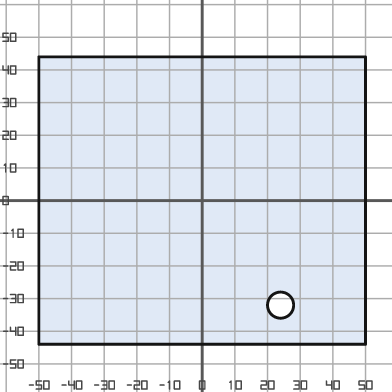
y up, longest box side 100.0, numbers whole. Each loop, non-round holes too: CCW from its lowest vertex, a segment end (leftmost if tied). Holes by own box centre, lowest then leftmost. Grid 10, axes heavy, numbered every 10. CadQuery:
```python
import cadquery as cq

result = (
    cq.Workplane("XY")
    .moveTo(-50.0, -44.0)
    .lineTo(50.0, -44.0)
    .lineTo(50.0, 44.0)
    .lineTo(-50.0, 44.0)
    .close()
    .moveTo(24.0, -32.0)
    .circle(4.0)
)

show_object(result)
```